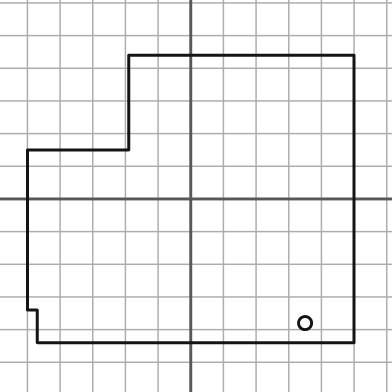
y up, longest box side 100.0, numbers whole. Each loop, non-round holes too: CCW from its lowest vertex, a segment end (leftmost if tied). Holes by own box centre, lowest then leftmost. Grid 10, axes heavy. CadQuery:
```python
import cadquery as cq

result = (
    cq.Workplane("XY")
    .moveTo(-47.0, -44.0)
    .lineTo(50.0, -44.0)
    .lineTo(50.0, 44.0)
    .lineTo(-19.0, 44.0)
    .lineTo(-19.0, 15.0)
    .lineTo(-50.0, 15.0)
    .lineTo(-50.0, -34.0)
    .lineTo(-47.0, -34.0)
    .close()
    .moveTo(35.0, -38.0)
    .circle(2.0)
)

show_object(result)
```